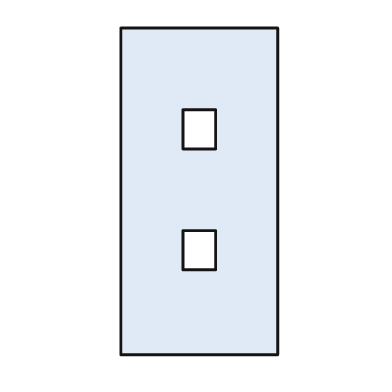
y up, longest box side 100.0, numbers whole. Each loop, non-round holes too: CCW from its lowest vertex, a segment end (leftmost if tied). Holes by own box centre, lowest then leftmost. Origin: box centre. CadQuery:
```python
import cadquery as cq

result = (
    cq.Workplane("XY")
    .moveTo(-24.0, -50.0)
    .lineTo(24.0, -50.0)
    .lineTo(24.0, 50.0)
    .lineTo(-24.0, 50.0)
    .close()
    .moveTo(-5.0, -24.0)
    .lineTo(5.0, -24.0)
    .lineTo(5.0, -12.0)
    .lineTo(-5.0, -12.0)
    .close()
    .moveTo(-5.0, 13.0)
    .lineTo(5.0, 13.0)
    .lineTo(5.0, 25.0)
    .lineTo(-5.0, 25.0)
    .close()
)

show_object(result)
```